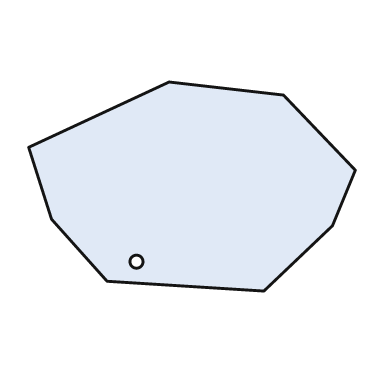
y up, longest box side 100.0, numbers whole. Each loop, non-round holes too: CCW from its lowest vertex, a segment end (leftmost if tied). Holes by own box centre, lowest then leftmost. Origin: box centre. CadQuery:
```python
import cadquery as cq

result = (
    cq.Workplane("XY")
    .moveTo(22.0, -32.0)
    .lineTo(43.0, -12.0)
    .lineTo(50.0, 5.0)
    .lineTo(28.0, 28.0)
    .lineTo(-7.0, 32.0)
    .lineTo(-50.0, 12.0)
    .lineTo(-43.0, -10.0)
    .lineTo(-26.0, -29.0)
    .close()
    .moveTo(-17.0, -23.0)
    .circle(2.0)
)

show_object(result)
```